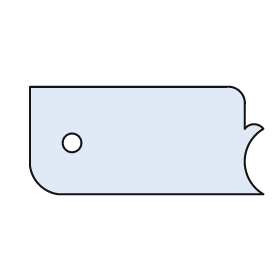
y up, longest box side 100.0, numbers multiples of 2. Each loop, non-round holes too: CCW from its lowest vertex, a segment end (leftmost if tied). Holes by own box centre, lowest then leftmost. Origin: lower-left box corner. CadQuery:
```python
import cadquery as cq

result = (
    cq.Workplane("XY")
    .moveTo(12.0, 0.0)
    .lineTo(100.0, 0.0)
    .threePointArc((92.0, 14.0), (100.0, 28.0))
    .threePointArc((96.0, 30.0), (92.0, 28.0))
    .lineTo(92.0, 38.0)
    .threePointArc((90.0, 44.0), (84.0, 46.0))
    .lineTo(0.0, 46.0)
    .lineTo(0.0, 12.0)
    .threePointArc((4.0, 4.0), (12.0, 0.0))
    .close()
    .moveTo(18.0, 22.0)
    .circle(4.0)
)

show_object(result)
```